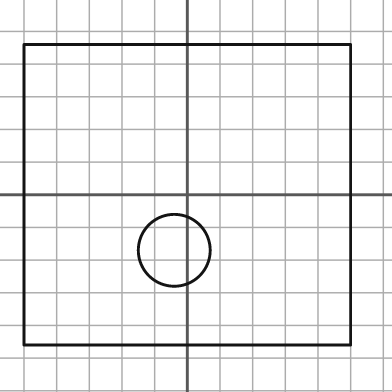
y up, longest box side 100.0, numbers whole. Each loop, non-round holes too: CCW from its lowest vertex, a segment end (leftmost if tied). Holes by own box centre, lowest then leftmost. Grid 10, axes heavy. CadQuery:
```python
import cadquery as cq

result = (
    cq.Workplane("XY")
    .moveTo(-50.0, -46.0)
    .lineTo(50.0, -46.0)
    .lineTo(50.0, 46.0)
    .lineTo(-50.0, 46.0)
    .close()
    .moveTo(-4.0, -17.0)
    .circle(11.0)
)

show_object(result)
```